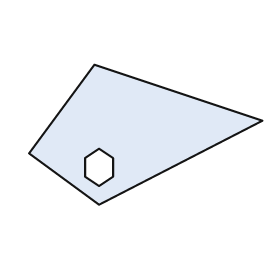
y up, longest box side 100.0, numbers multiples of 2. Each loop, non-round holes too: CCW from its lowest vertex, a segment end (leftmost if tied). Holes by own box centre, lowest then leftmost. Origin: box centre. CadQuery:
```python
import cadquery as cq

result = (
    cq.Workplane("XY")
    .moveTo(-20.0, -30.0)
    .lineTo(50.0, 6.0)
    .lineTo(-22.0, 30.0)
    .lineTo(-50.0, -8.0)
    .close()
    .moveTo(-20.0, -22.0)
    .lineTo(-14.0, -18.0)
    .lineTo(-14.0, -10.0)
    .lineTo(-20.0, -6.0)
    .lineTo(-26.0, -10.0)
    .lineTo(-26.0, -18.0)
    .close()
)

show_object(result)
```